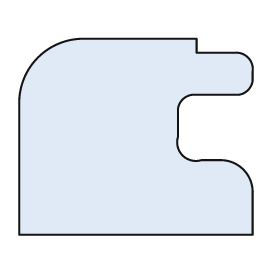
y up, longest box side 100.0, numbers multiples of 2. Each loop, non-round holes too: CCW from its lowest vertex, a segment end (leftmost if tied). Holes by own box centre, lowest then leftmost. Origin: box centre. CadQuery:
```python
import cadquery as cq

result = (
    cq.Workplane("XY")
    .moveTo(-50.0, -42.0)
    .lineTo(50.0, -42.0)
    .lineTo(50.0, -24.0)
    .threePointArc((46.0, -14.0), (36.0, -10.0))
    .lineTo(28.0, -10.0)
    .threePointArc((20.0, -8.0), (18.0, 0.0))
    .lineTo(18.0, 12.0)
    .threePointArc((20.0, 16.0), (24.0, 18.0))
    .lineTo(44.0, 18.0)
    .threePointArc((48.0, 20.0), (50.0, 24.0))
    .lineTo(50.0, 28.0)
    .threePointArc((48.0, 34.0), (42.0, 36.0))
    .lineTo(26.0, 36.0)
    .lineTo(26.0, 42.0)
    .lineTo(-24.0, 42.0)
    .threePointArc((-42.0, 34.0), (-50.0, 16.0))
    .close()
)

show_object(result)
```